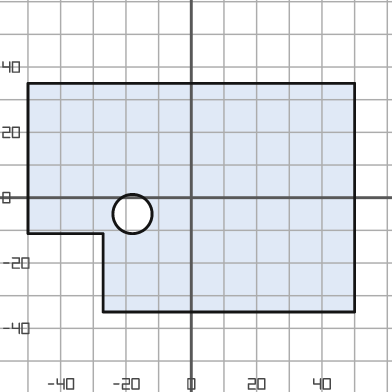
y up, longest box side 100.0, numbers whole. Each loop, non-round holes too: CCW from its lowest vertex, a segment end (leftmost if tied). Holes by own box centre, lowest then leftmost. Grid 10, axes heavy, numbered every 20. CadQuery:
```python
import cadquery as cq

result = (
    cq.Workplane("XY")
    .moveTo(-27.0, -35.0)
    .lineTo(50.0, -35.0)
    .lineTo(50.0, 35.0)
    .lineTo(-50.0, 35.0)
    .lineTo(-50.0, -11.0)
    .lineTo(-27.0, -11.0)
    .close()
    .moveTo(-18.0, -5.0)
    .circle(6.0)
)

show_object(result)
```